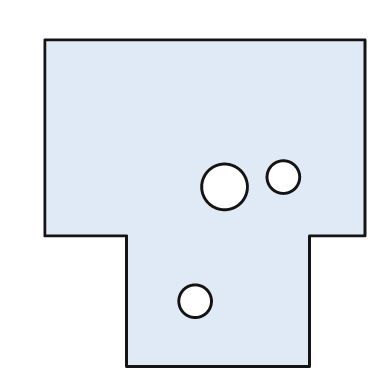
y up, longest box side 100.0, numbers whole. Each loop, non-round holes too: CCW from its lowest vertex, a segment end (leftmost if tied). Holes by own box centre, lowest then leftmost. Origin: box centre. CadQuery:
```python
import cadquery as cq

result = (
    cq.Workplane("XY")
    .moveTo(-24.0, -50.0)
    .lineTo(32.0, -50.0)
    .lineTo(32.0, -10.0)
    .lineTo(49.0, -10.0)
    .lineTo(49.0, 50.0)
    .lineTo(-49.0, 50.0)
    .lineTo(-49.0, -10.0)
    .lineTo(-24.0, -10.0)
    .close()
    .moveTo(-3.0, -30.0)
    .circle(5.0)
    .moveTo(6.0, 5.0)
    .circle(7.0)
    .moveTo(24.0, 8.0)
    .circle(5.0)
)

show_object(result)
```